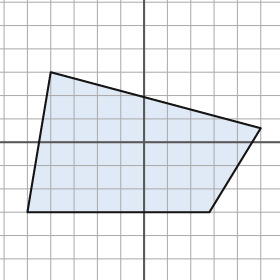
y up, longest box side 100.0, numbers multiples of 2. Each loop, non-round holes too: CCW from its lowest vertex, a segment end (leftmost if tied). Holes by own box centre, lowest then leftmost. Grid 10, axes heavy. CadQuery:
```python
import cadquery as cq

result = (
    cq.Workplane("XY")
    .moveTo(-50.0, -30.0)
    .lineTo(28.0, -30.0)
    .lineTo(50.0, 6.0)
    .lineTo(-40.0, 30.0)
    .close()
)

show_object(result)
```